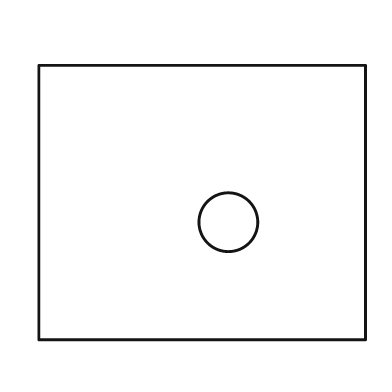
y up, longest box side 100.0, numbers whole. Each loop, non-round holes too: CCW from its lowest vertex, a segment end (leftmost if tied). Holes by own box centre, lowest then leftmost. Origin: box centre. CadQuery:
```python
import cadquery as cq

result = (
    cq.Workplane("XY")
    .moveTo(-50.0, -42.0)
    .lineTo(50.0, -42.0)
    .lineTo(50.0, 42.0)
    .lineTo(-50.0, 42.0)
    .close()
    .moveTo(8.0, -6.0)
    .circle(9.0)
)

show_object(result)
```